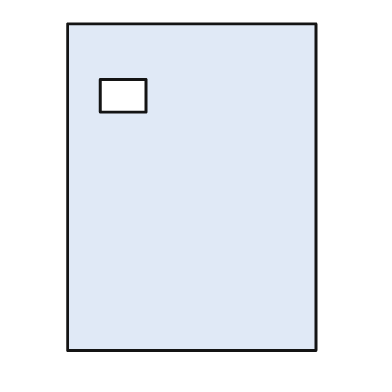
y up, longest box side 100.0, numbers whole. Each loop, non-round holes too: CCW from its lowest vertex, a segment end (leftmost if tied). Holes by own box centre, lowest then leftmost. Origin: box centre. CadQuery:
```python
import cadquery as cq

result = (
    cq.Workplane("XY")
    .moveTo(-38.0, -50.0)
    .lineTo(38.0, -50.0)
    .lineTo(38.0, 50.0)
    .lineTo(-38.0, 50.0)
    .close()
    .moveTo(-28.0, 23.0)
    .lineTo(-14.0, 23.0)
    .lineTo(-14.0, 33.0)
    .lineTo(-28.0, 33.0)
    .close()
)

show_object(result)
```